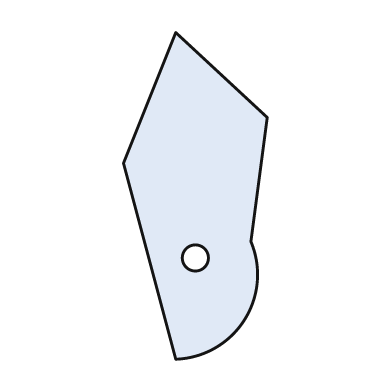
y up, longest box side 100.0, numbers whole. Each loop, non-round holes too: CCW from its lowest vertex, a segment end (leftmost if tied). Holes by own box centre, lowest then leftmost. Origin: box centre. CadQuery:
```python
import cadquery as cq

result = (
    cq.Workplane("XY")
    .moveTo(-6.0, -50.0)
    .threePointArc((15.0, -38.0), (17.0, -14.0))
    .lineTo(22.0, 24.0)
    .lineTo(-6.0, 50.0)
    .lineTo(-22.0, 10.0)
    .close()
    .moveTo(0.0, -19.0)
    .circle(4.0)
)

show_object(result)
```